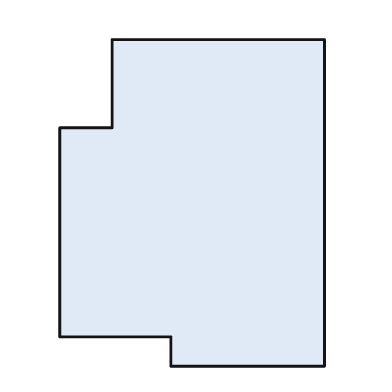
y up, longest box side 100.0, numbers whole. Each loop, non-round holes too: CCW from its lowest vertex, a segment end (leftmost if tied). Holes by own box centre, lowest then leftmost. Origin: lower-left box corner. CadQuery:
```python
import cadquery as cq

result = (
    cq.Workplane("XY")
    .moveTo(34.0, 0.0)
    .lineTo(81.0, 0.0)
    .lineTo(81.0, 100.0)
    .lineTo(16.0, 100.0)
    .lineTo(16.0, 73.0)
    .lineTo(0.0, 73.0)
    .lineTo(0.0, 9.0)
    .lineTo(34.0, 9.0)
    .close()
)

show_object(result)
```